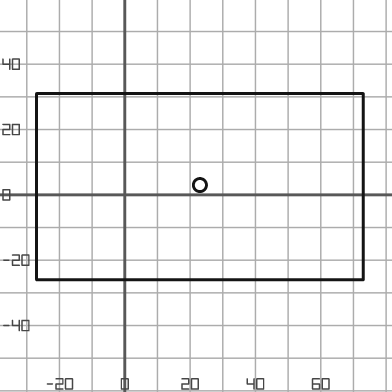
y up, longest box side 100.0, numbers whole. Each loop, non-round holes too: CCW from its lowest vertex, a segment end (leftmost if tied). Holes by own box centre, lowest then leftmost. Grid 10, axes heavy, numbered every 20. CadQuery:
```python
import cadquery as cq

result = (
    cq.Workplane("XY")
    .moveTo(-27.0, -26.0)
    .lineTo(73.0, -26.0)
    .lineTo(73.0, 31.0)
    .lineTo(-27.0, 31.0)
    .close()
    .moveTo(23.0, 3.0)
    .circle(2.0)
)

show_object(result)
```